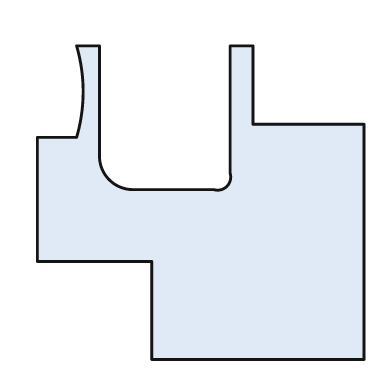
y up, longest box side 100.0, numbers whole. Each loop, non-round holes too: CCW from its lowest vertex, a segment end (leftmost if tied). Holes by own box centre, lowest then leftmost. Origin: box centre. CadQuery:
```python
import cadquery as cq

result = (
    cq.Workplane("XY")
    .moveTo(-15.0, -48.0)
    .lineTo(50.0, -48.0)
    .lineTo(50.0, 24.0)
    .lineTo(16.0, 24.0)
    .lineTo(16.0, 48.0)
    .lineTo(9.0, 48.0)
    .lineTo(9.0, 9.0)
    .threePointArc((8.0, 5.0), (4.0, 4.0))
    .lineTo(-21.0, 4.0)
    .threePointArc((-28.0, 7.0), (-31.0, 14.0))
    .lineTo(-31.0, 48.0)
    .lineTo(-38.0, 48.0)
    .threePointArc((-36.0, 34.0), (-38.0, 20.0))
    .lineTo(-50.0, 20.0)
    .lineTo(-50.0, -18.0)
    .lineTo(-15.0, -18.0)
    .close()
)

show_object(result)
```